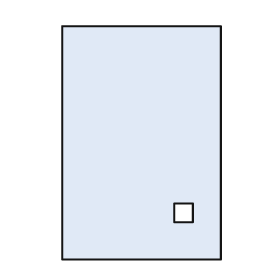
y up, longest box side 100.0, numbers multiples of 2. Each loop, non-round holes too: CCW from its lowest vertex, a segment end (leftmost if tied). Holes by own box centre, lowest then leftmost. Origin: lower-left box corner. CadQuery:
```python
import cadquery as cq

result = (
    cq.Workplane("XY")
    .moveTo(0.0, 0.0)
    .lineTo(68.0, 0.0)
    .lineTo(68.0, 100.0)
    .lineTo(0.0, 100.0)
    .close()
    .moveTo(48.0, 16.0)
    .lineTo(56.0, 16.0)
    .lineTo(56.0, 24.0)
    .lineTo(48.0, 24.0)
    .close()
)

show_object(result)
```